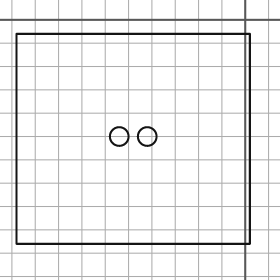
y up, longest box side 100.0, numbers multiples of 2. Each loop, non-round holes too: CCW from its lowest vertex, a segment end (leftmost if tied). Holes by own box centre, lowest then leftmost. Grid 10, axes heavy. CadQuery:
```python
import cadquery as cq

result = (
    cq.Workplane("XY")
    .moveTo(-98.0, -96.0)
    .lineTo(2.0, -96.0)
    .lineTo(2.0, -6.0)
    .lineTo(-98.0, -6.0)
    .close()
    .moveTo(-54.0, -50.0)
    .circle(4.0)
    .moveTo(-42.0, -50.0)
    .circle(4.0)
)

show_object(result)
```